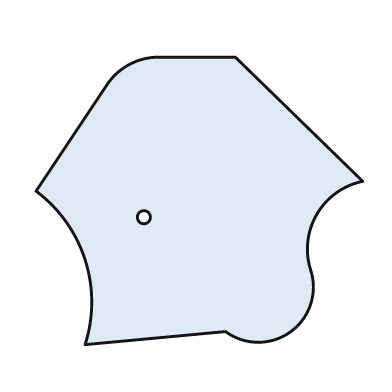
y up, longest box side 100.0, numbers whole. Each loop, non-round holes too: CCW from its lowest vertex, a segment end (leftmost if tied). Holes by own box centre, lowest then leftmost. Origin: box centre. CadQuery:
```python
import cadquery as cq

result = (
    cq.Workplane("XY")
    .moveTo(-35.0, -44.0)
    .lineTo(8.0, -40.0)
    .threePointArc((28.0, -40.0), (34.0, -21.0))
    .threePointArc((36.0, -4.0), (50.0, 6.0))
    .lineTo(11.0, 44.0)
    .lineTo(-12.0, 44.0)
    .threePointArc((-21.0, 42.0), (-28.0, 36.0))
    .lineTo(-50.0, 3.0)
    .threePointArc((-35.0, -18.0), (-35.0, -44.0))
    .close()
    .moveTo(-17.0, -5.0)
    .circle(2.0)
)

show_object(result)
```